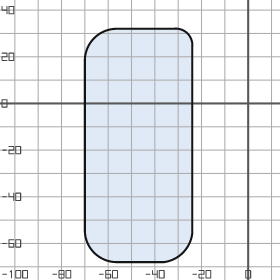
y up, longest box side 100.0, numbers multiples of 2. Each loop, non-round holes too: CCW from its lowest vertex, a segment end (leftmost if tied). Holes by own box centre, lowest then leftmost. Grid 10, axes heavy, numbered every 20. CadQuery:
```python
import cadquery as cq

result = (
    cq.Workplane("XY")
    .moveTo(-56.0, -68.0)
    .lineTo(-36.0, -68.0)
    .threePointArc((-28.0, -64.0), (-24.0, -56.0))
    .lineTo(-24.0, 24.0)
    .threePointArc((-26.0, 30.0), (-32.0, 32.0))
    .lineTo(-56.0, 32.0)
    .threePointArc((-66.0, 28.0), (-70.0, 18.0))
    .lineTo(-70.0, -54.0)
    .threePointArc((-66.0, -64.0), (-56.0, -68.0))
    .close()
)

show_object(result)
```